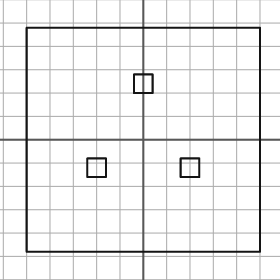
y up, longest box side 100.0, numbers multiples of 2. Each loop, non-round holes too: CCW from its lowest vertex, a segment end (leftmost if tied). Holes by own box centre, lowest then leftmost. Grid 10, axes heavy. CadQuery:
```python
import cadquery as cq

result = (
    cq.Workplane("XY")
    .moveTo(-50.0, -48.0)
    .lineTo(50.0, -48.0)
    .lineTo(50.0, 48.0)
    .lineTo(-50.0, 48.0)
    .close()
    .moveTo(-24.0, -16.0)
    .lineTo(-16.0, -16.0)
    .lineTo(-16.0, -8.0)
    .lineTo(-24.0, -8.0)
    .close()
    .moveTo(16.0, -16.0)
    .lineTo(24.0, -16.0)
    .lineTo(24.0, -8.0)
    .lineTo(16.0, -8.0)
    .close()
    .moveTo(-4.0, 20.0)
    .lineTo(4.0, 20.0)
    .lineTo(4.0, 28.0)
    .lineTo(-4.0, 28.0)
    .close()
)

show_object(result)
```